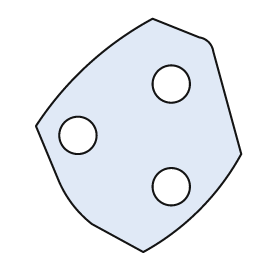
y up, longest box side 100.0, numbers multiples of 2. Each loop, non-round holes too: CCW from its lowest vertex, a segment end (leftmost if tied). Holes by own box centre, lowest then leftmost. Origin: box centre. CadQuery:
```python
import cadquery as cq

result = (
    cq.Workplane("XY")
    .moveTo(2.0, -50.0)
    .threePointArc((26.0, -32.0), (44.0, -8.0))
    .lineTo(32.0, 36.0)
    .threePointArc((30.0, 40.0), (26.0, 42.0))
    .lineTo(6.0, 50.0)
    .threePointArc((-22.0, 30.0), (-44.0, 4.0))
    .lineTo(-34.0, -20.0)
    .threePointArc((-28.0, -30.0), (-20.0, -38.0))
    .close()
    .moveTo(14.0, -22.0)
    .circle(8.0)
    .moveTo(-26.0, 0.0)
    .circle(8.0)
    .moveTo(14.0, 22.0)
    .circle(8.0)
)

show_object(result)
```